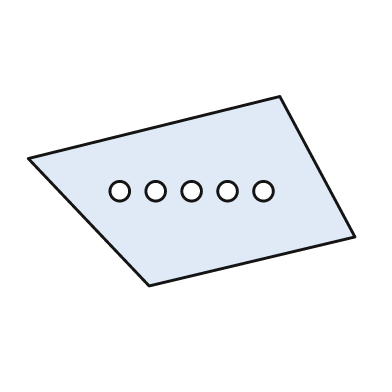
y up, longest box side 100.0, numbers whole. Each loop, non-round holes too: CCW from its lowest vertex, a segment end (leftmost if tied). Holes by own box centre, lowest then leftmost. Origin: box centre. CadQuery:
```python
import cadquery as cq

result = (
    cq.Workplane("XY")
    .moveTo(-13.0, -29.0)
    .lineTo(50.0, -14.0)
    .lineTo(27.0, 29.0)
    .lineTo(-50.0, 10.0)
    .close()
    .moveTo(-22.0, 0.0)
    .circle(3.0)
    .moveTo(-11.0, 0.0)
    .circle(3.0)
    .moveTo(0.0, 0.0)
    .circle(3.0)
    .moveTo(11.0, 0.0)
    .circle(3.0)
    .moveTo(22.0, 0.0)
    .circle(3.0)
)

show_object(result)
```